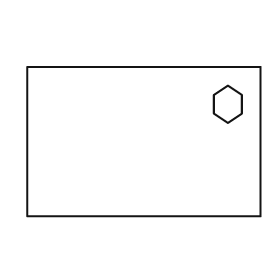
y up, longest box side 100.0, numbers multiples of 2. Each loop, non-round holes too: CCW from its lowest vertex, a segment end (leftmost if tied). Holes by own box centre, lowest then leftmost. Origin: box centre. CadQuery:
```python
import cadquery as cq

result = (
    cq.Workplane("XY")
    .moveTo(-50.0, -32.0)
    .lineTo(50.0, -32.0)
    .lineTo(50.0, 32.0)
    .lineTo(-50.0, 32.0)
    .close()
    .moveTo(36.0, 8.0)
    .lineTo(42.0, 12.0)
    .lineTo(42.0, 20.0)
    .lineTo(36.0, 24.0)
    .lineTo(30.0, 20.0)
    .lineTo(30.0, 12.0)
    .close()
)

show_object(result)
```